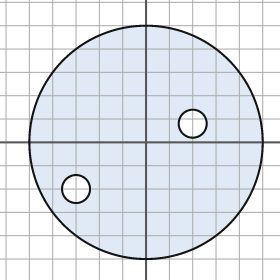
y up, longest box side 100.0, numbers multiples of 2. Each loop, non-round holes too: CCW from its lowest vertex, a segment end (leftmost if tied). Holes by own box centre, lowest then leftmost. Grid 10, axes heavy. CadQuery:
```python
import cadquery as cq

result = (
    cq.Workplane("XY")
    .moveTo(0.0, 0.0)
    .circle(50.0)
    .moveTo(-30.0, -20.0)
    .circle(6.0)
    .moveTo(20.0, 8.0)
    .circle(6.0)
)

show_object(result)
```